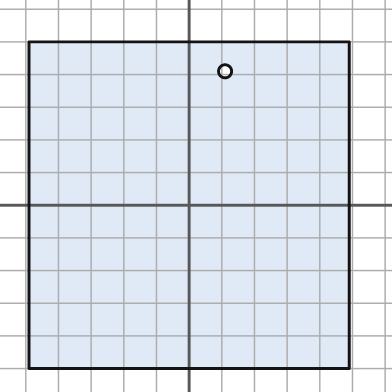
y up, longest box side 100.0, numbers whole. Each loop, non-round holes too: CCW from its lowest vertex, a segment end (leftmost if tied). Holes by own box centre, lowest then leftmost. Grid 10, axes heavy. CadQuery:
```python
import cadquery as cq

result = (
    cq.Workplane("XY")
    .moveTo(-49.0, -50.0)
    .lineTo(49.0, -50.0)
    .lineTo(49.0, 50.0)
    .lineTo(-49.0, 50.0)
    .close()
    .moveTo(11.0, 41.0)
    .circle(2.0)
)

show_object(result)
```